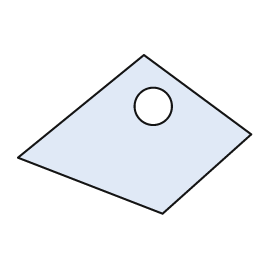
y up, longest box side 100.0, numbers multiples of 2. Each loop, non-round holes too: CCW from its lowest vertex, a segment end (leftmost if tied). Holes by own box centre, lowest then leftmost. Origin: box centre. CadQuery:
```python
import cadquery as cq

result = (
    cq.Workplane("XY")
    .moveTo(12.0, -34.0)
    .lineTo(50.0, 0.0)
    .lineTo(4.0, 34.0)
    .lineTo(-50.0, -10.0)
    .close()
    .moveTo(8.0, 12.0)
    .circle(8.0)
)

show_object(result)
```